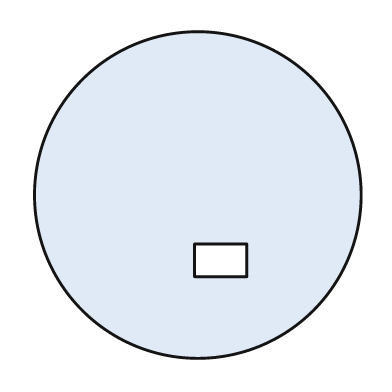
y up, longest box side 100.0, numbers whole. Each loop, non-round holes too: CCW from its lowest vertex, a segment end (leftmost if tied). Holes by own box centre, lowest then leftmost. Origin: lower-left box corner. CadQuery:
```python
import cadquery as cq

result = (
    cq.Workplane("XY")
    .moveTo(50.0, 50.0)
    .circle(50.0)
    .moveTo(49.0, 25.0)
    .lineTo(65.0, 25.0)
    .lineTo(65.0, 35.0)
    .lineTo(49.0, 35.0)
    .close()
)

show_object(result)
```